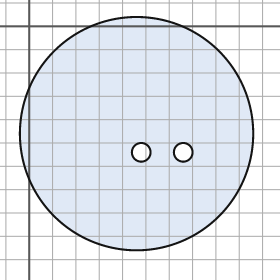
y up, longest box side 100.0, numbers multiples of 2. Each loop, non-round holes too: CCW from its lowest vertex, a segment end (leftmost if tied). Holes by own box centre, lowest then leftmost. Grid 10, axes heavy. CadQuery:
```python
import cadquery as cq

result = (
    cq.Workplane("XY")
    .moveTo(46.0, -46.0)
    .circle(50.0)
    .moveTo(48.0, -54.0)
    .circle(4.0)
    .moveTo(66.0, -54.0)
    .circle(4.0)
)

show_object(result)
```